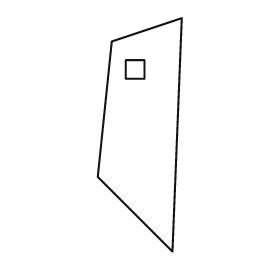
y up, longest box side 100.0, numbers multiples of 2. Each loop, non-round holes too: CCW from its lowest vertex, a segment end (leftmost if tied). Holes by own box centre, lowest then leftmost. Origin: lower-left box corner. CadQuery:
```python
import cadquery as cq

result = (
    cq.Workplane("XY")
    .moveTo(32.0, 0.0)
    .lineTo(36.0, 100.0)
    .lineTo(6.0, 90.0)
    .lineTo(0.0, 32.0)
    .close()
    .moveTo(12.0, 74.0)
    .lineTo(20.0, 74.0)
    .lineTo(20.0, 82.0)
    .lineTo(12.0, 82.0)
    .close()
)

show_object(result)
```